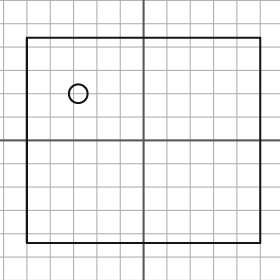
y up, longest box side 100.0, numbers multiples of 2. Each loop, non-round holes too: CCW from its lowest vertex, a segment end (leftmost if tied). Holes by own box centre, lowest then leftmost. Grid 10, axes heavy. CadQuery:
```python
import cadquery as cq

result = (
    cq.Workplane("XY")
    .moveTo(-50.0, -44.0)
    .lineTo(50.0, -44.0)
    .lineTo(50.0, 44.0)
    .lineTo(-50.0, 44.0)
    .close()
    .moveTo(-28.0, 20.0)
    .circle(4.0)
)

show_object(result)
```